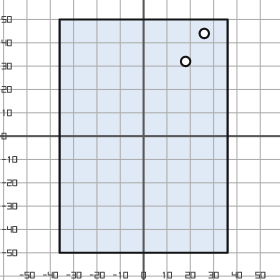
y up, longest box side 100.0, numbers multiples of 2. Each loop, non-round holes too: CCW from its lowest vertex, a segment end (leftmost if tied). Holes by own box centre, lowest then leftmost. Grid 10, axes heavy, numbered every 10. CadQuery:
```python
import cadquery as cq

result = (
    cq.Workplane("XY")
    .moveTo(-36.0, -50.0)
    .lineTo(36.0, -50.0)
    .lineTo(36.0, 50.0)
    .lineTo(-36.0, 50.0)
    .close()
    .moveTo(18.0, 32.0)
    .circle(2.0)
    .moveTo(26.0, 44.0)
    .circle(2.0)
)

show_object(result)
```